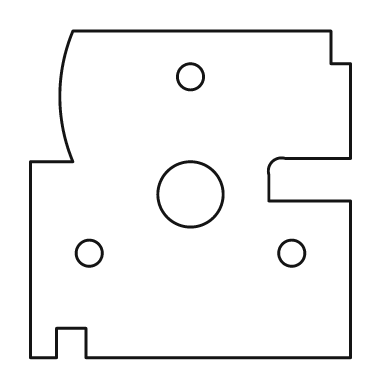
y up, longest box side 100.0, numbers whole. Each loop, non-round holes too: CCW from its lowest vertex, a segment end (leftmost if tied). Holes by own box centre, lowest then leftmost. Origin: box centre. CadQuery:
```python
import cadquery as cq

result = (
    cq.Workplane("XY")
    .moveTo(-49.0, -50.0)
    .lineTo(-41.0, -50.0)
    .lineTo(-41.0, -41.0)
    .lineTo(-32.0, -41.0)
    .lineTo(-32.0, -50.0)
    .lineTo(49.0, -50.0)
    .lineTo(49.0, -2.0)
    .lineTo(24.0, -2.0)
    .lineTo(24.0, 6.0)
    .threePointArc((25.0, 10.0), (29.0, 11.0))
    .lineTo(49.0, 11.0)
    .lineTo(49.0, 40.0)
    .lineTo(43.0, 40.0)
    .lineTo(43.0, 50.0)
    .lineTo(-36.0, 50.0)
    .threePointArc((-40.0, 30.0), (-36.0, 10.0))
    .lineTo(-49.0, 10.0)
    .close()
    .moveTo(-31.0, -18.0)
    .circle(4.0)
    .moveTo(31.0, -18.0)
    .circle(4.0)
    .moveTo(0.0, 0.0)
    .circle(10.0)
    .moveTo(0.0, 36.0)
    .circle(4.0)
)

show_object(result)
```